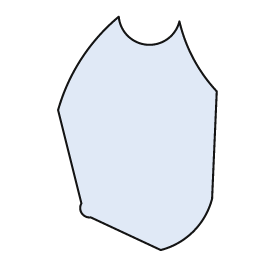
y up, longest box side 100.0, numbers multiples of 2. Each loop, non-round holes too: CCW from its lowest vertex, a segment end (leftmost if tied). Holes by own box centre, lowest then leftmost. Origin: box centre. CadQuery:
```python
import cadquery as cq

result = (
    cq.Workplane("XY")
    .moveTo(10.0, -50.0)
    .threePointArc((24.0, -42.0), (32.0, -28.0))
    .lineTo(34.0, 18.0)
    .threePointArc((24.0, 32.0), (18.0, 48.0))
    .threePointArc((4.0, 38.0), (-8.0, 50.0))
    .threePointArc((-24.0, 32.0), (-34.0, 10.0))
    .lineTo(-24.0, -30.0)
    .threePointArc((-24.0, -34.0), (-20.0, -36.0))
    .close()
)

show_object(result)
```